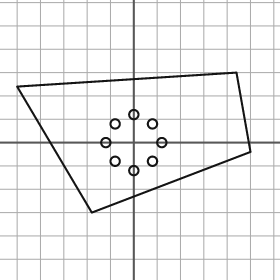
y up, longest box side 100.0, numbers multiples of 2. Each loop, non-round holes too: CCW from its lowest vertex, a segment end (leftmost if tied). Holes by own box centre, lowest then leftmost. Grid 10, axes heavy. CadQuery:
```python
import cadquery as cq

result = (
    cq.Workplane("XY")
    .moveTo(-18.0, -30.0)
    .lineTo(50.0, -4.0)
    .lineTo(44.0, 30.0)
    .lineTo(-50.0, 24.0)
    .close()
    .moveTo(0.0, -12.0)
    .circle(2.0)
    .moveTo(-8.0, -8.0)
    .circle(2.0)
    .moveTo(8.0, -8.0)
    .circle(2.0)
    .moveTo(-12.0, 0.0)
    .circle(2.0)
    .moveTo(12.0, 0.0)
    .circle(2.0)
    .moveTo(-8.0, 8.0)
    .circle(2.0)
    .moveTo(8.0, 8.0)
    .circle(2.0)
    .moveTo(0.0, 12.0)
    .circle(2.0)
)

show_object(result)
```